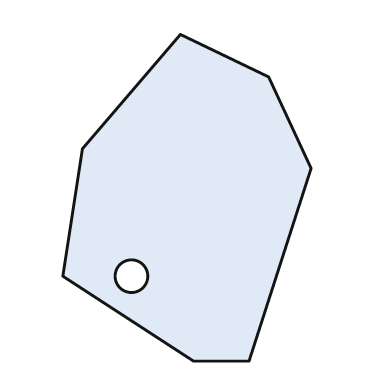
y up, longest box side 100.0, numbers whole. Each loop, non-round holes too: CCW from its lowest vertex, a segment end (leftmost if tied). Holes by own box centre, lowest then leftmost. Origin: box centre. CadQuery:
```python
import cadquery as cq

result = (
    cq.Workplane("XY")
    .moveTo(2.0, -50.0)
    .lineTo(19.0, -50.0)
    .lineTo(38.0, 9.0)
    .lineTo(25.0, 37.0)
    .lineTo(-2.0, 50.0)
    .lineTo(-32.0, 15.0)
    .lineTo(-38.0, -24.0)
    .close()
    .moveTo(-17.0, -24.0)
    .circle(5.0)
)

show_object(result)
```